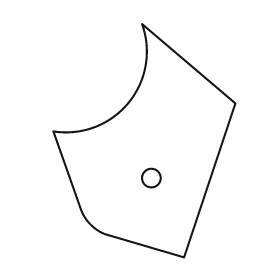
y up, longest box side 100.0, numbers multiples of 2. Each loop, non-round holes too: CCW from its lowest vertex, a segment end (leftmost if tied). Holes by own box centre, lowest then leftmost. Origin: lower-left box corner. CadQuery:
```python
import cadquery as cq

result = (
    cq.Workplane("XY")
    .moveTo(56.0, 0.0)
    .lineTo(78.0, 66.0)
    .lineTo(38.0, 100.0)
    .threePointArc((32.0, 66.0), (0.0, 54.0))
    .lineTo(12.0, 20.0)
    .threePointArc((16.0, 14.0), (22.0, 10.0))
    .close()
    .moveTo(42.0, 34.0)
    .circle(4.0)
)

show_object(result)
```